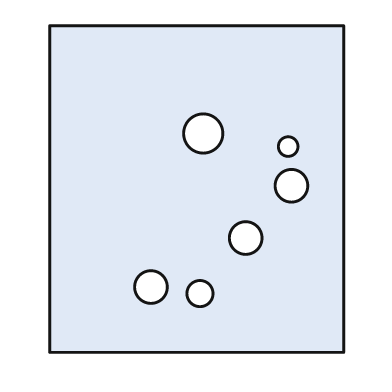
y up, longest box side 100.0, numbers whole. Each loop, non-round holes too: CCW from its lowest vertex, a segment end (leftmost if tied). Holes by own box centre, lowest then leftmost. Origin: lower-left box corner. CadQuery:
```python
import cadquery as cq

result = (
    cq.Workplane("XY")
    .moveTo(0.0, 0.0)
    .lineTo(90.0, 0.0)
    .lineTo(90.0, 100.0)
    .lineTo(0.0, 100.0)
    .close()
    .moveTo(46.0, 18.0)
    .circle(4.0)
    .moveTo(31.0, 20.0)
    .circle(5.0)
    .moveTo(60.0, 35.0)
    .circle(5.0)
    .moveTo(74.0, 51.0)
    .circle(5.0)
    .moveTo(73.0, 63.0)
    .circle(3.0)
    .moveTo(47.0, 67.0)
    .circle(6.0)
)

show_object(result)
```